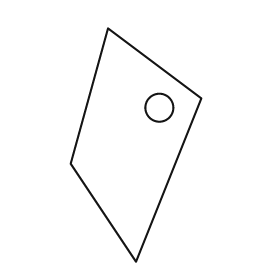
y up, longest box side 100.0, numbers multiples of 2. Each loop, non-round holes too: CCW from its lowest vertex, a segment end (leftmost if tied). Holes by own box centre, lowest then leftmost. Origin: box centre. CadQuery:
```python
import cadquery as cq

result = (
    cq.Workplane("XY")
    .moveTo(0.0, -50.0)
    .lineTo(28.0, 20.0)
    .lineTo(-12.0, 50.0)
    .lineTo(-28.0, -8.0)
    .close()
    .moveTo(10.0, 16.0)
    .circle(6.0)
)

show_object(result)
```